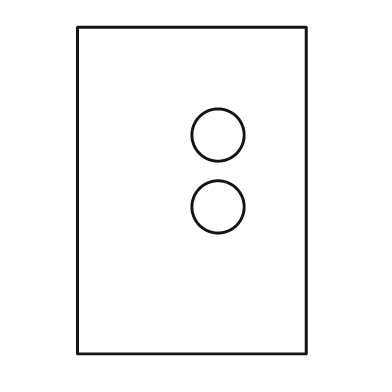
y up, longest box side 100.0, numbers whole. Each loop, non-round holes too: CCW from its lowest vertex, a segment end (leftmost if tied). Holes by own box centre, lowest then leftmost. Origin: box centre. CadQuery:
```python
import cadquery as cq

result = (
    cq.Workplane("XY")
    .moveTo(-35.0, -50.0)
    .lineTo(35.0, -50.0)
    .lineTo(35.0, 50.0)
    .lineTo(-35.0, 50.0)
    .close()
    .moveTo(8.0, -5.0)
    .circle(8.0)
    .moveTo(8.0, 17.0)
    .circle(8.0)
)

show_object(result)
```